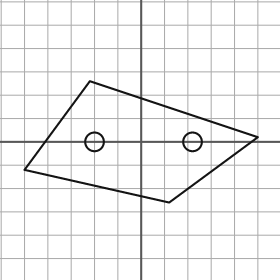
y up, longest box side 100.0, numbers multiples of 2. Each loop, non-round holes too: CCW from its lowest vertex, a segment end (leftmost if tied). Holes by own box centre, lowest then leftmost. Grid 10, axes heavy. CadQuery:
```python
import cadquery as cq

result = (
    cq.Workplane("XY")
    .moveTo(12.0, -26.0)
    .lineTo(50.0, 2.0)
    .lineTo(-22.0, 26.0)
    .lineTo(-50.0, -12.0)
    .close()
    .moveTo(-20.0, 0.0)
    .circle(4.0)
    .moveTo(22.0, 0.0)
    .circle(4.0)
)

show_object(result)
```